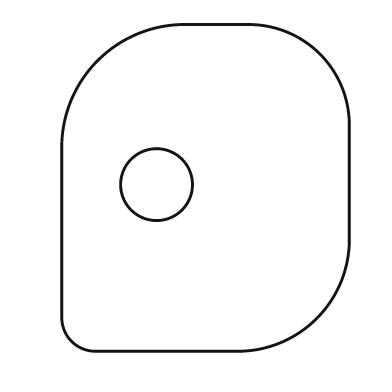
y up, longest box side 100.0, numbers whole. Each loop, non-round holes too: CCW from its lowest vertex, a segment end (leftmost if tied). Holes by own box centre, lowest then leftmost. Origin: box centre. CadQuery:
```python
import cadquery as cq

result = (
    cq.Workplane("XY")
    .moveTo(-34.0, -50.0)
    .lineTo(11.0, -50.0)
    .threePointArc((34.0, -40.0), (44.0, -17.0))
    .lineTo(44.0, 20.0)
    .threePointArc((35.0, 41.0), (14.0, 50.0))
    .lineTo(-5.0, 50.0)
    .threePointArc((-33.0, 39.0), (-44.0, 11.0))
    .lineTo(-44.0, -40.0)
    .threePointArc((-41.0, -47.0), (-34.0, -50.0))
    .close()
    .moveTo(-15.0, 1.0)
    .circle(11.0)
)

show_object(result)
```